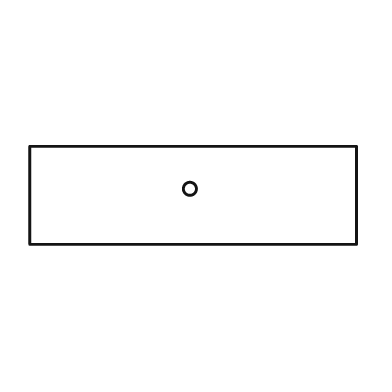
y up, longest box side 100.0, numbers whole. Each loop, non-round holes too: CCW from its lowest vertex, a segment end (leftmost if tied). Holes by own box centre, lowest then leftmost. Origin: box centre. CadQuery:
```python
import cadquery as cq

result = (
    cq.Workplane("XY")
    .moveTo(-50.0, -15.0)
    .lineTo(50.0, -15.0)
    .lineTo(50.0, 15.0)
    .lineTo(-50.0, 15.0)
    .close()
    .moveTo(-1.0, 2.0)
    .circle(2.0)
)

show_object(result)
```